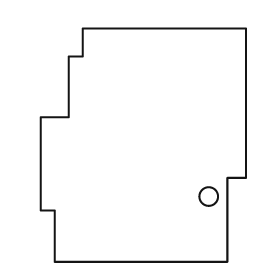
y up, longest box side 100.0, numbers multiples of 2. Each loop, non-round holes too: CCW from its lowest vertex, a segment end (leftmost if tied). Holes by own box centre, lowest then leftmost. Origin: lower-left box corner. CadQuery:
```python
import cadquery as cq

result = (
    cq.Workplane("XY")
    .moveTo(6.0, 0.0)
    .lineTo(80.0, 0.0)
    .lineTo(80.0, 36.0)
    .lineTo(88.0, 36.0)
    .lineTo(88.0, 100.0)
    .lineTo(18.0, 100.0)
    .lineTo(18.0, 88.0)
    .lineTo(12.0, 88.0)
    .lineTo(12.0, 62.0)
    .lineTo(0.0, 62.0)
    .lineTo(0.0, 22.0)
    .lineTo(6.0, 22.0)
    .close()
    .moveTo(72.0, 28.0)
    .circle(4.0)
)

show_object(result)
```